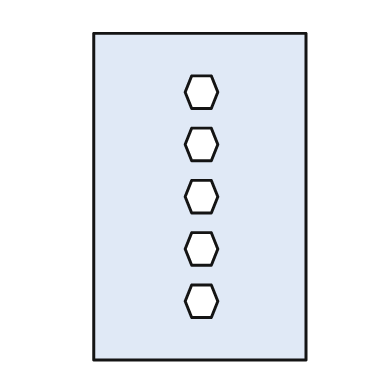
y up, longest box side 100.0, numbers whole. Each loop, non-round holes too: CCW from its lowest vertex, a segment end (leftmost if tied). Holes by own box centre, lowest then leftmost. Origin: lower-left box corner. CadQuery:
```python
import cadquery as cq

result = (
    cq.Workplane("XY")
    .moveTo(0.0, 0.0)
    .lineTo(65.0, 0.0)
    .lineTo(65.0, 100.0)
    .lineTo(0.0, 100.0)
    .close()
    .moveTo(30.0, 13.0)
    .lineTo(36.0, 13.0)
    .lineTo(38.0, 18.0)
    .lineTo(36.0, 23.0)
    .lineTo(30.0, 23.0)
    .lineTo(28.0, 18.0)
    .close()
    .moveTo(30.0, 29.0)
    .lineTo(36.0, 29.0)
    .lineTo(38.0, 34.0)
    .lineTo(36.0, 39.0)
    .lineTo(30.0, 39.0)
    .lineTo(28.0, 34.0)
    .close()
    .moveTo(30.0, 45.0)
    .lineTo(36.0, 45.0)
    .lineTo(38.0, 50.0)
    .lineTo(36.0, 55.0)
    .lineTo(30.0, 55.0)
    .lineTo(28.0, 50.0)
    .close()
    .moveTo(30.0, 61.0)
    .lineTo(36.0, 61.0)
    .lineTo(38.0, 66.0)
    .lineTo(36.0, 71.0)
    .lineTo(30.0, 71.0)
    .lineTo(28.0, 66.0)
    .close()
    .moveTo(30.0, 77.0)
    .lineTo(36.0, 77.0)
    .lineTo(38.0, 82.0)
    .lineTo(36.0, 87.0)
    .lineTo(30.0, 87.0)
    .lineTo(28.0, 82.0)
    .close()
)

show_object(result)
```